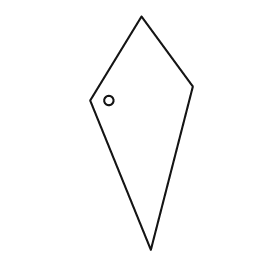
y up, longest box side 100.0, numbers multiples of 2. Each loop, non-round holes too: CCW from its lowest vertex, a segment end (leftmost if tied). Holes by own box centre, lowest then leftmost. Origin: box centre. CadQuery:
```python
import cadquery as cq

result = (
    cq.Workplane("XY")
    .moveTo(4.0, -50.0)
    .lineTo(22.0, 20.0)
    .lineTo(0.0, 50.0)
    .lineTo(-22.0, 14.0)
    .close()
    .moveTo(-14.0, 14.0)
    .circle(2.0)
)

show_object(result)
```